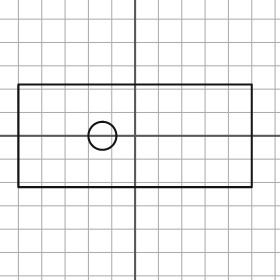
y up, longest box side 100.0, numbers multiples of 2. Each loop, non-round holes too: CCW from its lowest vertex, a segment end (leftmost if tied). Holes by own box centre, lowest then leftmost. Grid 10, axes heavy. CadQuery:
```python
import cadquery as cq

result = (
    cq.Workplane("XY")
    .moveTo(-50.0, -22.0)
    .lineTo(50.0, -22.0)
    .lineTo(50.0, 22.0)
    .lineTo(-50.0, 22.0)
    .close()
    .moveTo(-14.0, 0.0)
    .circle(6.0)
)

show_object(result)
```